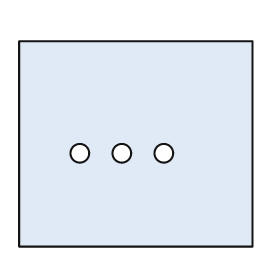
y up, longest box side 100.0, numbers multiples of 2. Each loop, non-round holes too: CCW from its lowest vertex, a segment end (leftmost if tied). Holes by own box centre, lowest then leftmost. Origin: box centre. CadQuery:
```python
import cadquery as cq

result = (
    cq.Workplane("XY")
    .moveTo(-50.0, -44.0)
    .lineTo(50.0, -44.0)
    .lineTo(50.0, 44.0)
    .lineTo(-50.0, 44.0)
    .close()
    .moveTo(-24.0, -4.0)
    .circle(4.0)
    .moveTo(-6.0, -4.0)
    .circle(4.0)
    .moveTo(12.0, -4.0)
    .circle(4.0)
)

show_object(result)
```